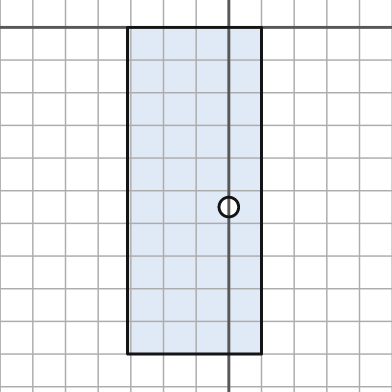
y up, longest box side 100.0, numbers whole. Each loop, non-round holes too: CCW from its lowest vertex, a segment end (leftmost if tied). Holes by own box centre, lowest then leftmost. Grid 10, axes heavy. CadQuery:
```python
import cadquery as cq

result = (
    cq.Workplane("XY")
    .moveTo(-31.0, -100.0)
    .lineTo(10.0, -100.0)
    .lineTo(10.0, 0.0)
    .lineTo(-31.0, 0.0)
    .close()
    .moveTo(0.0, -55.0)
    .circle(3.0)
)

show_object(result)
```